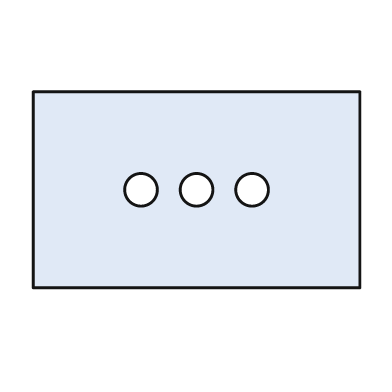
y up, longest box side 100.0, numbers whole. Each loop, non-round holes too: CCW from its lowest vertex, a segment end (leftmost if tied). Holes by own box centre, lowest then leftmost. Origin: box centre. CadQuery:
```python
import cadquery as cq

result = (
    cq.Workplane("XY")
    .moveTo(-50.0, -30.0)
    .lineTo(50.0, -30.0)
    .lineTo(50.0, 30.0)
    .lineTo(-50.0, 30.0)
    .close()
    .moveTo(-17.0, 0.0)
    .circle(5.0)
    .moveTo(0.0, 0.0)
    .circle(5.0)
    .moveTo(17.0, 0.0)
    .circle(5.0)
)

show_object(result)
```